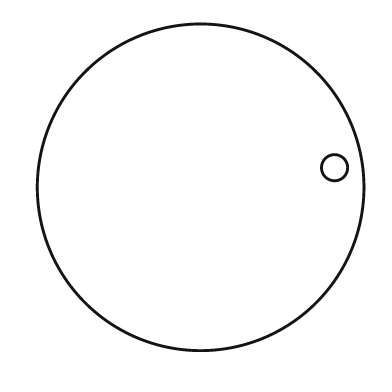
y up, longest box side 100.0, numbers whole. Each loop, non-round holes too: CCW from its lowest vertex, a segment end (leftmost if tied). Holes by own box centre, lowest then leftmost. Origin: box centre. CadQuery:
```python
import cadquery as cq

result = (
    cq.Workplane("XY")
    .moveTo(0.0, 0.0)
    .circle(50.0)
    .moveTo(41.0, 6.0)
    .circle(4.0)
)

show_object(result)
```